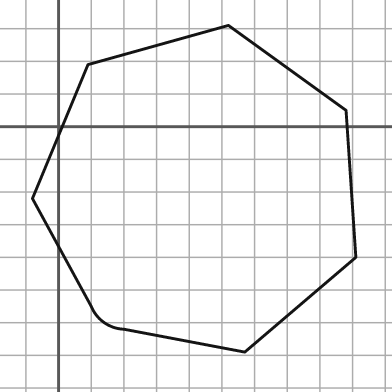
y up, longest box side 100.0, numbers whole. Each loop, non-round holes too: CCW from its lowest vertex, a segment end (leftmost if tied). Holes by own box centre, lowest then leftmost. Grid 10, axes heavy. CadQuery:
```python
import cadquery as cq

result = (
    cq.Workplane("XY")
    .moveTo(57.0, -69.0)
    .lineTo(91.0, -40.0)
    .lineTo(88.0, 5.0)
    .lineTo(52.0, 31.0)
    .lineTo(9.0, 19.0)
    .lineTo(-8.0, -22.0)
    .lineTo(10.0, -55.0)
    .threePointArc((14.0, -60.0), (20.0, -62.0))
    .close()
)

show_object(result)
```